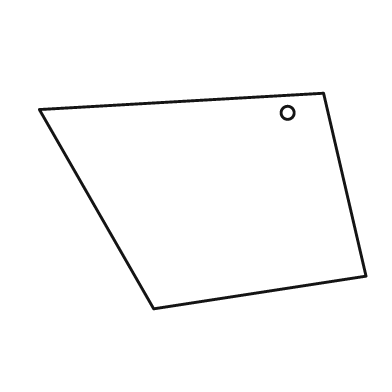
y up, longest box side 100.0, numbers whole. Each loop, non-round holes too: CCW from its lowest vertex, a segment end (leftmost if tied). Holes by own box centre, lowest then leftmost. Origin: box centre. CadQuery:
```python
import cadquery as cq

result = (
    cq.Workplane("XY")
    .moveTo(-15.0, -33.0)
    .lineTo(50.0, -23.0)
    .lineTo(37.0, 33.0)
    .lineTo(-50.0, 28.0)
    .close()
    .moveTo(26.0, 27.0)
    .circle(2.0)
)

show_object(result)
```